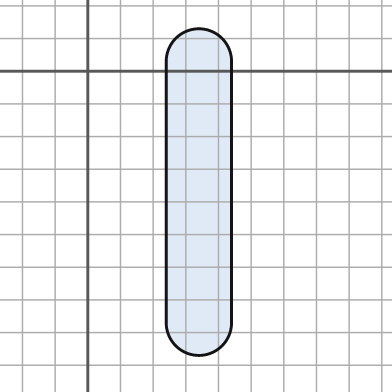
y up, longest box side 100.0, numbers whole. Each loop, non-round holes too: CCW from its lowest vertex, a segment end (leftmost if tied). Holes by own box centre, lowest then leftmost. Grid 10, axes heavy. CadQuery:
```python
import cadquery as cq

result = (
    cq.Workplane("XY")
    .moveTo(24.0, -77.0)
    .threePointArc((34.0, -87.0), (44.0, -77.0))
    .lineTo(44.0, 3.0)
    .threePointArc((34.0, 13.0), (24.0, 3.0))
    .close()
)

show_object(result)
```